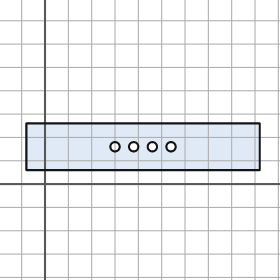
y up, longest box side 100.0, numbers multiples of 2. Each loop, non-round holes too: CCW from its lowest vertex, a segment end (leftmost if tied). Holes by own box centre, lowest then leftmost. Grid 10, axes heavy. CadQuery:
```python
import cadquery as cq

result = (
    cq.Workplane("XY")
    .moveTo(-8.0, 6.0)
    .lineTo(92.0, 6.0)
    .lineTo(92.0, 26.0)
    .lineTo(-8.0, 26.0)
    .close()
    .moveTo(30.0, 16.0)
    .circle(2.0)
    .moveTo(38.0, 16.0)
    .circle(2.0)
    .moveTo(46.0, 16.0)
    .circle(2.0)
    .moveTo(54.0, 16.0)
    .circle(2.0)
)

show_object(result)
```